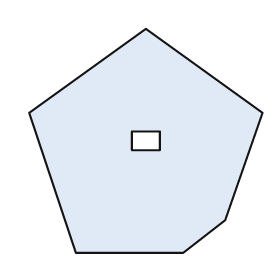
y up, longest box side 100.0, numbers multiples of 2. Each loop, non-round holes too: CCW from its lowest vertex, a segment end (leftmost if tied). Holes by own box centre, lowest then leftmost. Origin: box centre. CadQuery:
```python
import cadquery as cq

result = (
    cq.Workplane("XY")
    .moveTo(-30.0, -48.0)
    .lineTo(16.0, -48.0)
    .lineTo(34.0, -34.0)
    .lineTo(50.0, 12.0)
    .lineTo(0.0, 48.0)
    .lineTo(-50.0, 12.0)
    .close()
    .moveTo(-6.0, -4.0)
    .lineTo(6.0, -4.0)
    .lineTo(6.0, 4.0)
    .lineTo(-6.0, 4.0)
    .close()
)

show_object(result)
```